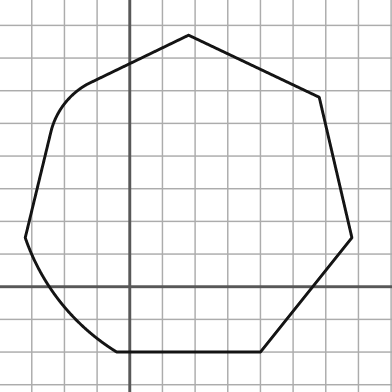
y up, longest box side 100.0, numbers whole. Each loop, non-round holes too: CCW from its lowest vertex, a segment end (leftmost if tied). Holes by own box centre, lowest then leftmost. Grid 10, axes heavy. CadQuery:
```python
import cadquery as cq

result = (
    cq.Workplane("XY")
    .moveTo(-4.0, -20.0)
    .lineTo(40.0, -20.0)
    .lineTo(68.0, 15.0)
    .lineTo(58.0, 58.0)
    .lineTo(18.0, 77.0)
    .lineTo(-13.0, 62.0)
    .threePointArc((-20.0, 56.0), (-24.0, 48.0))
    .lineTo(-32.0, 15.0)
    .threePointArc((-21.0, -5.0), (-4.0, -20.0))
    .close()
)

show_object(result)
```